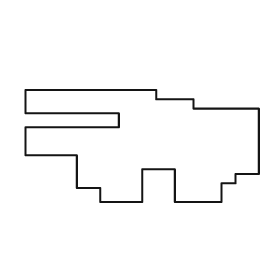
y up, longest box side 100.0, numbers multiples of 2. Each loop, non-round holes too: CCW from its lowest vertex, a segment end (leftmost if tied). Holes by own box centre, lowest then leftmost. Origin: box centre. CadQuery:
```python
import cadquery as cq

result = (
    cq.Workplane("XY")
    .moveTo(-18.0, -24.0)
    .lineTo(0.0, -24.0)
    .lineTo(0.0, -10.0)
    .lineTo(14.0, -10.0)
    .lineTo(14.0, -24.0)
    .lineTo(34.0, -24.0)
    .lineTo(34.0, -16.0)
    .lineTo(40.0, -16.0)
    .lineTo(40.0, -12.0)
    .lineTo(50.0, -12.0)
    .lineTo(50.0, 16.0)
    .lineTo(22.0, 16.0)
    .lineTo(22.0, 20.0)
    .lineTo(6.0, 20.0)
    .lineTo(6.0, 24.0)
    .lineTo(-50.0, 24.0)
    .lineTo(-50.0, 14.0)
    .lineTo(-10.0, 14.0)
    .lineTo(-10.0, 8.0)
    .lineTo(-50.0, 8.0)
    .lineTo(-50.0, -4.0)
    .lineTo(-28.0, -4.0)
    .lineTo(-28.0, -18.0)
    .lineTo(-18.0, -18.0)
    .close()
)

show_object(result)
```